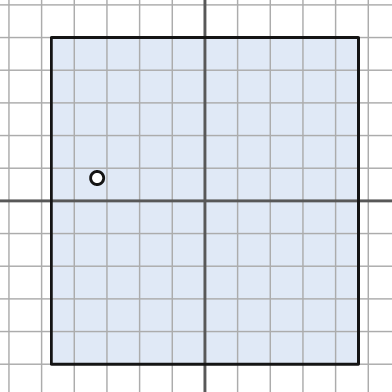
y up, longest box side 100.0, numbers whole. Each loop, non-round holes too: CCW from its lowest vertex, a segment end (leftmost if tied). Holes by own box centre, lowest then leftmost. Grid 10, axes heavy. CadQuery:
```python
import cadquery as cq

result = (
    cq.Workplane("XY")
    .moveTo(-47.0, -50.0)
    .lineTo(47.0, -50.0)
    .lineTo(47.0, 50.0)
    .lineTo(-47.0, 50.0)
    .close()
    .moveTo(-33.0, 7.0)
    .circle(2.0)
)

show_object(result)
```